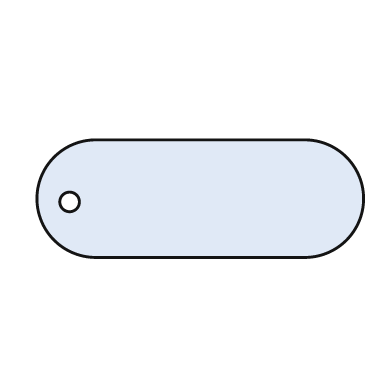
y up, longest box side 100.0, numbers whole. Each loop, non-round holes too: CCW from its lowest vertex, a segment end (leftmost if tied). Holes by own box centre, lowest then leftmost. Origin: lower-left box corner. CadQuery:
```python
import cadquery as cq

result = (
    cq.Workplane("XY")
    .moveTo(18.0, 0.0)
    .lineTo(82.0, 0.0)
    .threePointArc((100.0, 18.0), (82.0, 36.0))
    .lineTo(18.0, 36.0)
    .threePointArc((0.0, 18.0), (18.0, 0.0))
    .close()
    .moveTo(10.0, 17.0)
    .circle(3.0)
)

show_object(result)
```